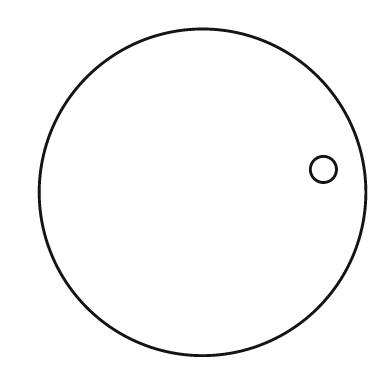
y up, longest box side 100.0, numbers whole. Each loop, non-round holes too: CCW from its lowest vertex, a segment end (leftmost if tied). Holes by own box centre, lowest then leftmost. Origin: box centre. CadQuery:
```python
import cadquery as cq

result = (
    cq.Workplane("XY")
    .moveTo(0.0, 0.0)
    .circle(50.0)
    .moveTo(37.0, 7.0)
    .circle(4.0)
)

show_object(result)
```